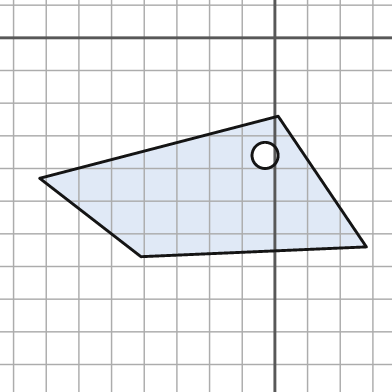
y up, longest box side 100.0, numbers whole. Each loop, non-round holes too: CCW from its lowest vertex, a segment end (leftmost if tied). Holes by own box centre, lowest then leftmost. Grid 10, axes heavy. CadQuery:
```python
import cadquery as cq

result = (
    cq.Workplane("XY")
    .moveTo(-41.0, -67.0)
    .lineTo(28.0, -64.0)
    .lineTo(1.0, -24.0)
    .lineTo(-72.0, -43.0)
    .close()
    .moveTo(-3.0, -36.0)
    .circle(4.0)
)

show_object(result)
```